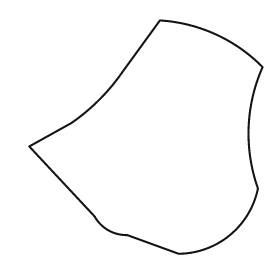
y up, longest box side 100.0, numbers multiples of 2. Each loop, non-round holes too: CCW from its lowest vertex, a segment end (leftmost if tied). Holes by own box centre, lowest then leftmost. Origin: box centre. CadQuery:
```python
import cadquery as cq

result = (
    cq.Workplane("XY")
    .moveTo(14.0, -50.0)
    .threePointArc((36.0, -42.0), (48.0, -22.0))
    .threePointArc((44.0, 4.0), (50.0, 30.0))
    .threePointArc((30.0, 44.0), (6.0, 50.0))
    .lineTo(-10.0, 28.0)
    .threePointArc((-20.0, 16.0), (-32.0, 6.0))
    .lineTo(-50.0, -4.0)
    .lineTo(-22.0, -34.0)
    .threePointArc((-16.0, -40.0), (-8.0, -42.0))
    .close()
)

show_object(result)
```